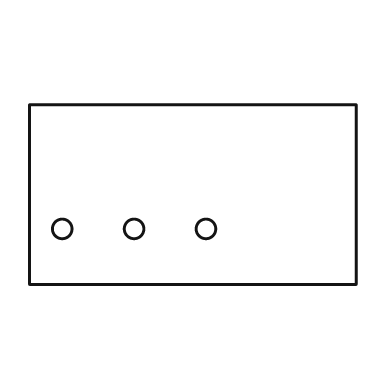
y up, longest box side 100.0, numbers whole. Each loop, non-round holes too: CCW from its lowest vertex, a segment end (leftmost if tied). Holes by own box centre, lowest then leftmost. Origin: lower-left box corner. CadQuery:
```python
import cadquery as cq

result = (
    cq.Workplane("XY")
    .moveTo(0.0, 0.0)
    .lineTo(100.0, 0.0)
    .lineTo(100.0, 55.0)
    .lineTo(0.0, 55.0)
    .close()
    .moveTo(10.0, 17.0)
    .circle(3.0)
    .moveTo(32.0, 17.0)
    .circle(3.0)
    .moveTo(54.0, 17.0)
    .circle(3.0)
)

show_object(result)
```